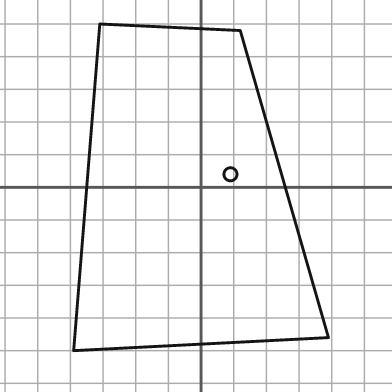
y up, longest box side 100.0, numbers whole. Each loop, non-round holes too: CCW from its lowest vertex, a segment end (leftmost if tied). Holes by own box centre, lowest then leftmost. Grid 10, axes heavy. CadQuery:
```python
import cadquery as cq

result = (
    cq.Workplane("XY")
    .moveTo(-39.0, -50.0)
    .lineTo(39.0, -46.0)
    .lineTo(12.0, 48.0)
    .lineTo(-31.0, 50.0)
    .close()
    .moveTo(9.0, 4.0)
    .circle(2.0)
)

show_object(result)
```